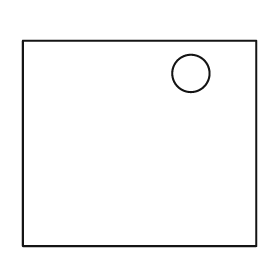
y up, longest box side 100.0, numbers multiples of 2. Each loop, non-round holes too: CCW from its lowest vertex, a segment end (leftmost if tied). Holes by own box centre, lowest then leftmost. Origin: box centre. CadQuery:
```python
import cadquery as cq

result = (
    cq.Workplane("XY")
    .moveTo(-50.0, -44.0)
    .lineTo(50.0, -44.0)
    .lineTo(50.0, 44.0)
    .lineTo(-50.0, 44.0)
    .close()
    .moveTo(22.0, 30.0)
    .circle(8.0)
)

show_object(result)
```